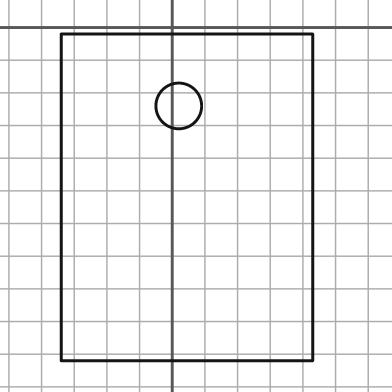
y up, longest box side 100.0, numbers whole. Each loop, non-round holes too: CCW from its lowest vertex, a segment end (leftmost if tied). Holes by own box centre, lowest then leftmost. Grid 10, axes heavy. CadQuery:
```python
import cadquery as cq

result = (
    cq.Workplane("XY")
    .moveTo(-34.0, -102.0)
    .lineTo(43.0, -102.0)
    .lineTo(43.0, -2.0)
    .lineTo(-34.0, -2.0)
    .close()
    .moveTo(2.0, -24.0)
    .circle(7.0)
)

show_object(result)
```